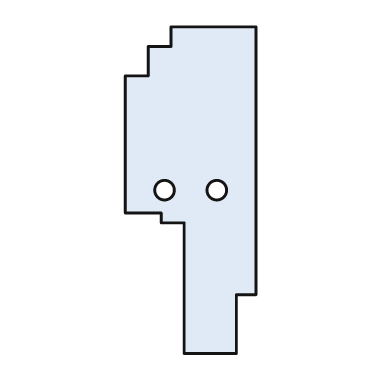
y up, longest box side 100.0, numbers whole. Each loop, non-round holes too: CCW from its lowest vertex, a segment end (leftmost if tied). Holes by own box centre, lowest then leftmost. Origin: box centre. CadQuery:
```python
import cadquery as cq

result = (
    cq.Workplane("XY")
    .moveTo(-2.0, -50.0)
    .lineTo(14.0, -50.0)
    .lineTo(14.0, -32.0)
    .lineTo(20.0, -32.0)
    .lineTo(20.0, 50.0)
    .lineTo(-6.0, 50.0)
    .lineTo(-6.0, 44.0)
    .lineTo(-13.0, 44.0)
    .lineTo(-13.0, 35.0)
    .lineTo(-20.0, 35.0)
    .lineTo(-20.0, -7.0)
    .lineTo(-9.0, -7.0)
    .lineTo(-9.0, -10.0)
    .lineTo(-2.0, -10.0)
    .close()
    .moveTo(-8.0, 0.0)
    .circle(3.0)
    .moveTo(8.0, 0.0)
    .circle(3.0)
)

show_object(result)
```